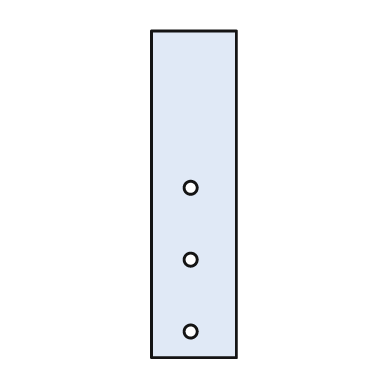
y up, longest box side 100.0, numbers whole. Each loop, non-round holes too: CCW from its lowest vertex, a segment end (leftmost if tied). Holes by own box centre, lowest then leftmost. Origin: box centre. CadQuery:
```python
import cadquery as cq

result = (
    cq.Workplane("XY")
    .moveTo(-13.0, -50.0)
    .lineTo(13.0, -50.0)
    .lineTo(13.0, 50.0)
    .lineTo(-13.0, 50.0)
    .close()
    .moveTo(-1.0, -42.0)
    .circle(2.0)
    .moveTo(-1.0, -20.0)
    .circle(2.0)
    .moveTo(-1.0, 2.0)
    .circle(2.0)
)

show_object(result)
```